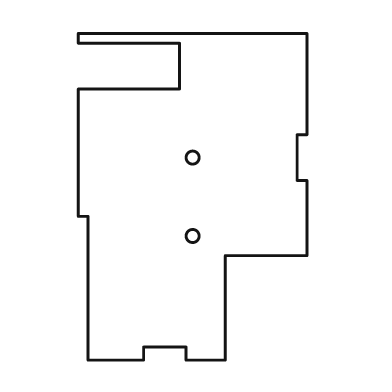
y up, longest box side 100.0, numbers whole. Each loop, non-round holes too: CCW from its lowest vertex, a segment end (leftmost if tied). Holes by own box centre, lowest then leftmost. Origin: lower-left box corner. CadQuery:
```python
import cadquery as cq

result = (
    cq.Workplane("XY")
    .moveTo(3.0, 0.0)
    .lineTo(20.0, 0.0)
    .lineTo(20.0, 4.0)
    .lineTo(33.0, 4.0)
    .lineTo(33.0, 0.0)
    .lineTo(45.0, 0.0)
    .lineTo(45.0, 32.0)
    .lineTo(70.0, 32.0)
    .lineTo(70.0, 55.0)
    .lineTo(67.0, 55.0)
    .lineTo(67.0, 69.0)
    .lineTo(70.0, 69.0)
    .lineTo(70.0, 100.0)
    .lineTo(0.0, 100.0)
    .lineTo(0.0, 97.0)
    .lineTo(31.0, 97.0)
    .lineTo(31.0, 83.0)
    .lineTo(0.0, 83.0)
    .lineTo(0.0, 44.0)
    .lineTo(3.0, 44.0)
    .close()
    .moveTo(35.0, 38.0)
    .circle(2.0)
    .moveTo(35.0, 62.0)
    .circle(2.0)
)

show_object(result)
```